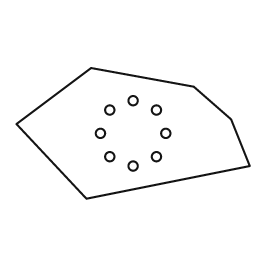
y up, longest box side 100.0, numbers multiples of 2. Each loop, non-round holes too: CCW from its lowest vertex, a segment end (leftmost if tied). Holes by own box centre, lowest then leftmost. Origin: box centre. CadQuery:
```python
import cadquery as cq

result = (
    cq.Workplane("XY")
    .moveTo(-20.0, -28.0)
    .lineTo(50.0, -14.0)
    .lineTo(42.0, 6.0)
    .lineTo(26.0, 20.0)
    .lineTo(-18.0, 28.0)
    .lineTo(-50.0, 4.0)
    .close()
    .moveTo(0.0, -14.0)
    .circle(2.0)
    .moveTo(-10.0, -10.0)
    .circle(2.0)
    .moveTo(10.0, -10.0)
    .circle(2.0)
    .moveTo(-14.0, 0.0)
    .circle(2.0)
    .moveTo(14.0, 0.0)
    .circle(2.0)
    .moveTo(-10.0, 10.0)
    .circle(2.0)
    .moveTo(10.0, 10.0)
    .circle(2.0)
    .moveTo(0.0, 14.0)
    .circle(2.0)
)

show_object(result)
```